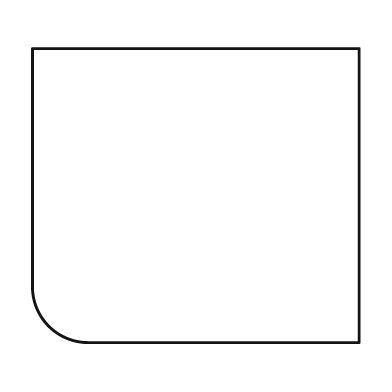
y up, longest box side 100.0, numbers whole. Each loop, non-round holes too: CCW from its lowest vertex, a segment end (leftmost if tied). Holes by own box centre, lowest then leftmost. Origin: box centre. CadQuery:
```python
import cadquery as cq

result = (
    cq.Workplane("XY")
    .moveTo(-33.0, -45.0)
    .lineTo(50.0, -45.0)
    .lineTo(50.0, 45.0)
    .lineTo(-50.0, 45.0)
    .lineTo(-50.0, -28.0)
    .threePointArc((-45.0, -40.0), (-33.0, -45.0))
    .close()
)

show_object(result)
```